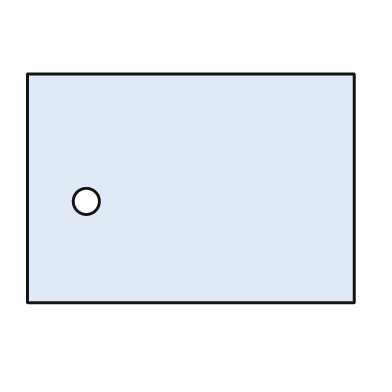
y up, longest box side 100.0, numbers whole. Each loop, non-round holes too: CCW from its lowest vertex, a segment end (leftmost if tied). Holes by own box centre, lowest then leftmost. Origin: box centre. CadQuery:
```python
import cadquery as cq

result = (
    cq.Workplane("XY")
    .moveTo(-50.0, -35.0)
    .lineTo(50.0, -35.0)
    .lineTo(50.0, 35.0)
    .lineTo(-50.0, 35.0)
    .close()
    .moveTo(-32.0, -4.0)
    .circle(4.0)
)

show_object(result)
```